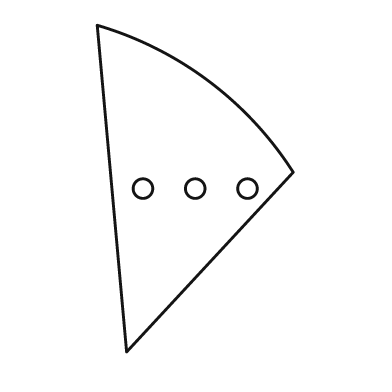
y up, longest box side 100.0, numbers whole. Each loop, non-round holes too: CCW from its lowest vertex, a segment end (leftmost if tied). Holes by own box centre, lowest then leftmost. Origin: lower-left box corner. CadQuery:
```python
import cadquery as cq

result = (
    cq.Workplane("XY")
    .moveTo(9.0, 0.0)
    .lineTo(60.0, 55.0)
    .threePointArc((34.0, 83.0), (0.0, 100.0))
    .close()
    .moveTo(14.0, 50.0)
    .circle(3.0)
    .moveTo(30.0, 50.0)
    .circle(3.0)
    .moveTo(46.0, 50.0)
    .circle(3.0)
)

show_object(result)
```